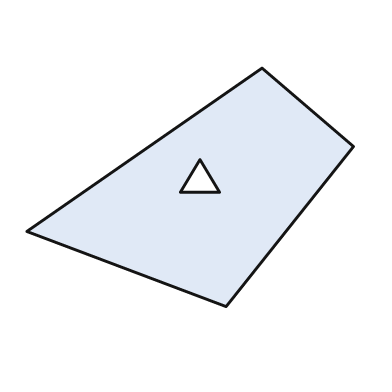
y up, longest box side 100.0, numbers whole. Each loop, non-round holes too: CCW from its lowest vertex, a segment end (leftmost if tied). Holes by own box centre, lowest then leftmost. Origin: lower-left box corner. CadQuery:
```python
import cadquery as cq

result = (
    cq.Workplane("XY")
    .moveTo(61.0, 0.0)
    .lineTo(100.0, 49.0)
    .lineTo(72.0, 73.0)
    .lineTo(0.0, 23.0)
    .close()
    .moveTo(47.0, 35.0)
    .lineTo(59.0, 35.0)
    .lineTo(53.0, 45.0)
    .close()
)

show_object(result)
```